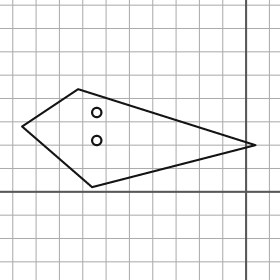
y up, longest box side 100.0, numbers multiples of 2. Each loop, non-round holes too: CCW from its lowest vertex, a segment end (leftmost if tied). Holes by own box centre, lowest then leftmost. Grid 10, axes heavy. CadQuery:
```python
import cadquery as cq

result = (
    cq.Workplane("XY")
    .moveTo(-66.0, 2.0)
    .lineTo(4.0, 20.0)
    .lineTo(-72.0, 44.0)
    .lineTo(-96.0, 28.0)
    .close()
    .moveTo(-64.0, 22.0)
    .circle(2.0)
    .moveTo(-64.0, 34.0)
    .circle(2.0)
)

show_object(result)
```